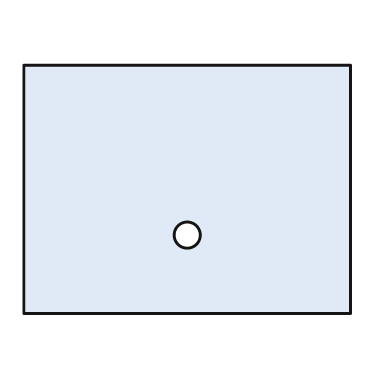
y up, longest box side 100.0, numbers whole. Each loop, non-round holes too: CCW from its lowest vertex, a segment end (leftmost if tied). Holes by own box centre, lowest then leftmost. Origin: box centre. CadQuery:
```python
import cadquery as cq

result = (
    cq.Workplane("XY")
    .moveTo(-50.0, -38.0)
    .lineTo(50.0, -38.0)
    .lineTo(50.0, 38.0)
    .lineTo(-50.0, 38.0)
    .close()
    .moveTo(0.0, -14.0)
    .circle(4.0)
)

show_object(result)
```